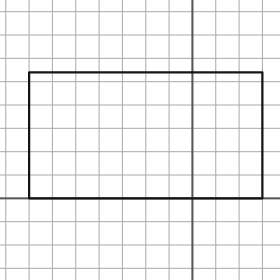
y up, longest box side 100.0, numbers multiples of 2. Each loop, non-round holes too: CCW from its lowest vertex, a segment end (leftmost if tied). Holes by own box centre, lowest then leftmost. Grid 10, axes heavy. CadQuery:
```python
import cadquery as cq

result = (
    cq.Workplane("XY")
    .moveTo(-70.0, 0.0)
    .lineTo(30.0, 0.0)
    .lineTo(30.0, 54.0)
    .lineTo(-70.0, 54.0)
    .close()
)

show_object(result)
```